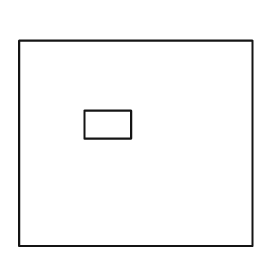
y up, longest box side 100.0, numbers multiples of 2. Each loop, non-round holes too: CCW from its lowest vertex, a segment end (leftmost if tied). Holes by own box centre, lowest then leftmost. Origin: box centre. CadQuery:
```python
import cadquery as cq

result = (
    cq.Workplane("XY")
    .moveTo(-50.0, -44.0)
    .lineTo(50.0, -44.0)
    .lineTo(50.0, 44.0)
    .lineTo(-50.0, 44.0)
    .close()
    .moveTo(-22.0, 2.0)
    .lineTo(-2.0, 2.0)
    .lineTo(-2.0, 14.0)
    .lineTo(-22.0, 14.0)
    .close()
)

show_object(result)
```